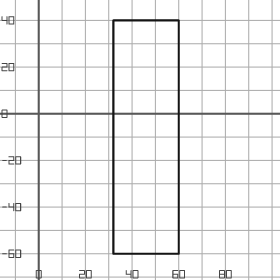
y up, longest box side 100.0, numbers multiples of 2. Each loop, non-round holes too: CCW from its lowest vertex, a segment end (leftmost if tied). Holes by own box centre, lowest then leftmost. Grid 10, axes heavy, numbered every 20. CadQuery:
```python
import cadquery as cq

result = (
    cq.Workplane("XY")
    .moveTo(32.0, -60.0)
    .lineTo(60.0, -60.0)
    .lineTo(60.0, 40.0)
    .lineTo(32.0, 40.0)
    .close()
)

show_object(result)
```